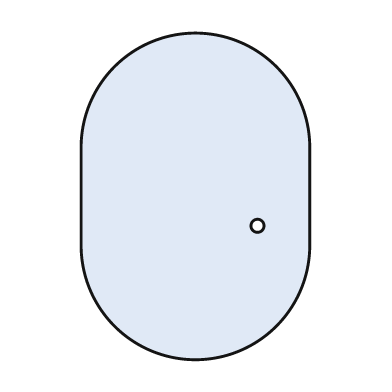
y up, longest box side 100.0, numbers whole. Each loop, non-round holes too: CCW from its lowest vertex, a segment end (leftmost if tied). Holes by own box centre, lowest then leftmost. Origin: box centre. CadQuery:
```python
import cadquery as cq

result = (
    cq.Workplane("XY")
    .moveTo(-35.0, -15.0)
    .threePointArc((0.0, -50.0), (35.0, -15.0))
    .lineTo(35.0, 15.0)
    .threePointArc((0.0, 50.0), (-35.0, 15.0))
    .close()
    .moveTo(19.0, -9.0)
    .circle(2.0)
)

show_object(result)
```